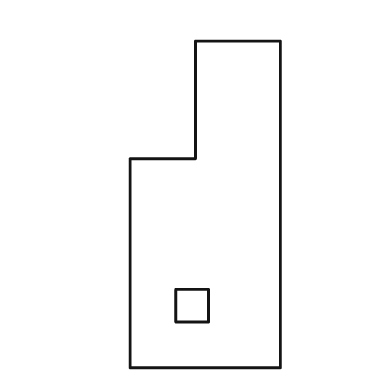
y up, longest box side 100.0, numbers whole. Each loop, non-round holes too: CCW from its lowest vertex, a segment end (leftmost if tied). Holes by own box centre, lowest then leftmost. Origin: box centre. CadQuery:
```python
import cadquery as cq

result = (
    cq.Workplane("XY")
    .moveTo(-23.0, -50.0)
    .lineTo(23.0, -50.0)
    .lineTo(23.0, 50.0)
    .lineTo(-3.0, 50.0)
    .lineTo(-3.0, 14.0)
    .lineTo(-23.0, 14.0)
    .close()
    .moveTo(-9.0, -36.0)
    .lineTo(1.0, -36.0)
    .lineTo(1.0, -26.0)
    .lineTo(-9.0, -26.0)
    .close()
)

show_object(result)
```